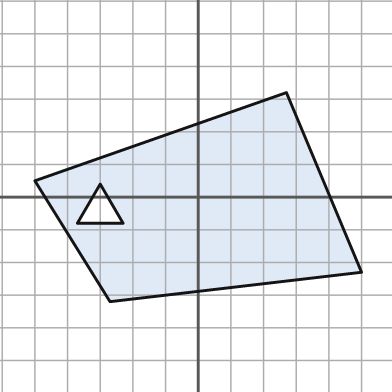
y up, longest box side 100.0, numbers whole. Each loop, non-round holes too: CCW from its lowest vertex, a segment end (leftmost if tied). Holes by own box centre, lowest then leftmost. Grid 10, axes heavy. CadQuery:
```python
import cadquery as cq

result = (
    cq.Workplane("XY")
    .moveTo(-27.0, -32.0)
    .lineTo(50.0, -23.0)
    .lineTo(27.0, 32.0)
    .lineTo(-50.0, 5.0)
    .close()
    .moveTo(-37.0, -8.0)
    .lineTo(-23.0, -8.0)
    .lineTo(-30.0, 4.0)
    .close()
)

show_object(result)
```